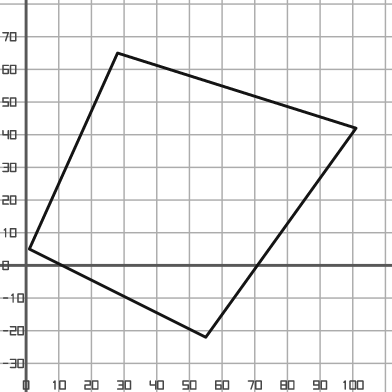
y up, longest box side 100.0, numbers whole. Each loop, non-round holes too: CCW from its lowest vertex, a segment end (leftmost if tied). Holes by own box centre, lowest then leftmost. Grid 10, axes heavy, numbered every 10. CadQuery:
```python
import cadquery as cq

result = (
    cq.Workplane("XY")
    .moveTo(55.0, -22.0)
    .lineTo(101.0, 42.0)
    .lineTo(28.0, 65.0)
    .lineTo(1.0, 5.0)
    .close()
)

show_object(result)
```